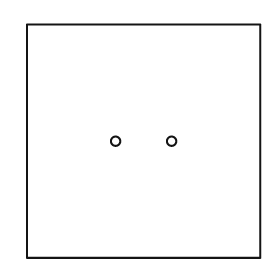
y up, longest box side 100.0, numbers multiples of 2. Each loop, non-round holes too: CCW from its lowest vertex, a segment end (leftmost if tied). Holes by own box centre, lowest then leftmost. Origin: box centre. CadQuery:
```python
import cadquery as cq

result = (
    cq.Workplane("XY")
    .moveTo(-50.0, -50.0)
    .lineTo(50.0, -50.0)
    .lineTo(50.0, 50.0)
    .lineTo(-50.0, 50.0)
    .close()
    .moveTo(-12.0, 0.0)
    .circle(2.0)
    .moveTo(12.0, 0.0)
    .circle(2.0)
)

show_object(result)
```